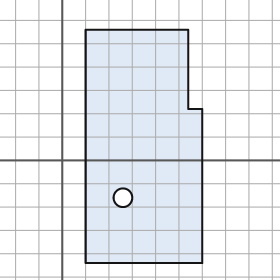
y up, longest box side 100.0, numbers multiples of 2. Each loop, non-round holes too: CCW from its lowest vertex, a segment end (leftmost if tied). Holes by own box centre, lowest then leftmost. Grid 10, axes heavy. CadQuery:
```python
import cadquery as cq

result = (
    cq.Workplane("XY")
    .moveTo(10.0, -44.0)
    .lineTo(60.0, -44.0)
    .lineTo(60.0, 22.0)
    .lineTo(54.0, 22.0)
    .lineTo(54.0, 56.0)
    .lineTo(10.0, 56.0)
    .close()
    .moveTo(26.0, -16.0)
    .circle(4.0)
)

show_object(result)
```